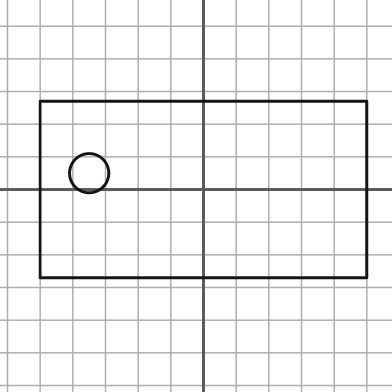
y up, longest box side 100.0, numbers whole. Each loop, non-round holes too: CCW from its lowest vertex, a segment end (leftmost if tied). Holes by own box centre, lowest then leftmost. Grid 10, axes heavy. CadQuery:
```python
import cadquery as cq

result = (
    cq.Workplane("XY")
    .moveTo(-50.0, -27.0)
    .lineTo(50.0, -27.0)
    .lineTo(50.0, 27.0)
    .lineTo(-50.0, 27.0)
    .close()
    .moveTo(-35.0, 5.0)
    .circle(6.0)
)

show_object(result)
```